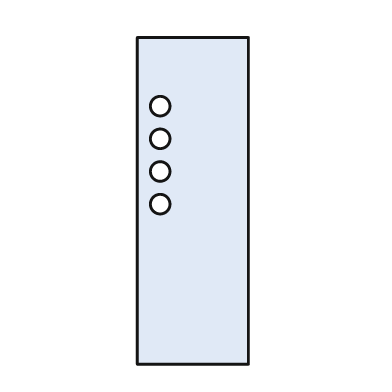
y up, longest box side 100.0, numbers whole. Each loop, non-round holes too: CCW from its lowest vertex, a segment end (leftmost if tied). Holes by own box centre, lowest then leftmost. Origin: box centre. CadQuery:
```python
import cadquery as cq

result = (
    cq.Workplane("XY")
    .moveTo(-17.0, -50.0)
    .lineTo(17.0, -50.0)
    .lineTo(17.0, 50.0)
    .lineTo(-17.0, 50.0)
    .close()
    .moveTo(-10.0, -1.0)
    .circle(3.0)
    .moveTo(-10.0, 9.0)
    .circle(3.0)
    .moveTo(-10.0, 19.0)
    .circle(3.0)
    .moveTo(-10.0, 29.0)
    .circle(3.0)
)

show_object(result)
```